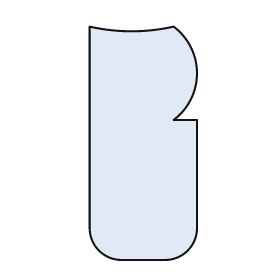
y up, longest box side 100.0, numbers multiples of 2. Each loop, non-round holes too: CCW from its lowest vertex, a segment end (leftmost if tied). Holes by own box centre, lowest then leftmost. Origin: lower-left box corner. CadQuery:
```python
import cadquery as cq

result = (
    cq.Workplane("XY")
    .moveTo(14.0, 0.0)
    .lineTo(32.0, 0.0)
    .threePointArc((42.0, 4.0), (46.0, 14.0))
    .lineTo(46.0, 60.0)
    .lineTo(36.0, 60.0)
    .threePointArc((46.0, 80.0), (36.0, 100.0))
    .threePointArc((18.0, 98.0), (0.0, 100.0))
    .lineTo(0.0, 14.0)
    .threePointArc((4.0, 4.0), (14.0, 0.0))
    .close()
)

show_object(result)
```